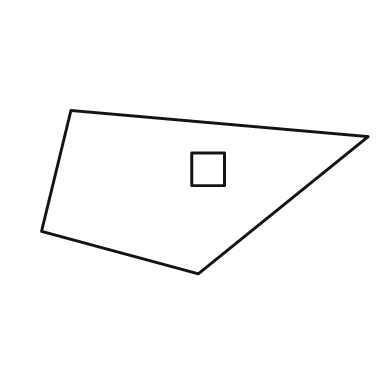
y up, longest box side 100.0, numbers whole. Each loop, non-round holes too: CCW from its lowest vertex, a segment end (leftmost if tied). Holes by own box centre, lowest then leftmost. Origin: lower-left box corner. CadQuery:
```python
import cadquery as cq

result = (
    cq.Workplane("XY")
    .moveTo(48.0, 0.0)
    .lineTo(100.0, 42.0)
    .lineTo(9.0, 50.0)
    .lineTo(0.0, 13.0)
    .close()
    .moveTo(46.0, 27.0)
    .lineTo(56.0, 27.0)
    .lineTo(56.0, 37.0)
    .lineTo(46.0, 37.0)
    .close()
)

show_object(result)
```